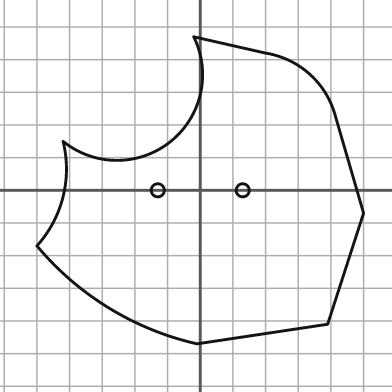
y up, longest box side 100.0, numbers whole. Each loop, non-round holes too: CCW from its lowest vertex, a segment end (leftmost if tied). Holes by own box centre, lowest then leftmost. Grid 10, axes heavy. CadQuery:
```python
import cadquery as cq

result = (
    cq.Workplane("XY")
    .moveTo(-1.0, -47.0)
    .lineTo(39.0, -41.0)
    .lineTo(50.0, -7.0)
    .lineTo(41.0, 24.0)
    .threePointArc((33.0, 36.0), (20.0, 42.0))
    .lineTo(-2.0, 47.0)
    .threePointArc((-9.0, 15.0), (-42.0, 15.0))
    .threePointArc((-42.0, -2.0), (-50.0, -17.0))
    .threePointArc((-28.0, -36.0), (-1.0, -47.0))
    .close()
    .moveTo(-13.0, 0.0)
    .circle(2.0)
    .moveTo(13.0, 0.0)
    .circle(2.0)
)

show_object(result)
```